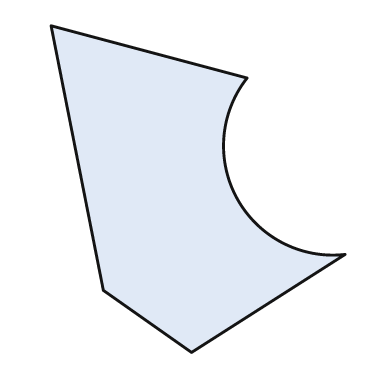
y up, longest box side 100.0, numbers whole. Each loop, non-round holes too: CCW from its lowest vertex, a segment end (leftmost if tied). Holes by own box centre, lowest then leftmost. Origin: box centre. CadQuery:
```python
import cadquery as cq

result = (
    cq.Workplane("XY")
    .moveTo(-2.0, -50.0)
    .lineTo(45.0, -20.0)
    .threePointArc((12.0, -3.0), (15.0, 34.0))
    .lineTo(-45.0, 50.0)
    .lineTo(-29.0, -31.0)
    .close()
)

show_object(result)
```